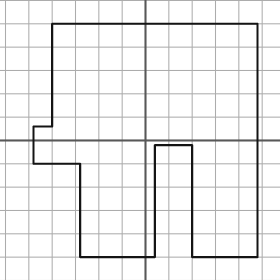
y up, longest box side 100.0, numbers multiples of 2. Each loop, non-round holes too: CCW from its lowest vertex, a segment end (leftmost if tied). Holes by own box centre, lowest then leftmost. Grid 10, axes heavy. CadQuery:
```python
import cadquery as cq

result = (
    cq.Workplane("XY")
    .moveTo(-28.0, -50.0)
    .lineTo(4.0, -50.0)
    .lineTo(4.0, -2.0)
    .lineTo(20.0, -2.0)
    .lineTo(20.0, -50.0)
    .lineTo(48.0, -50.0)
    .lineTo(48.0, 50.0)
    .lineTo(-40.0, 50.0)
    .lineTo(-40.0, 6.0)
    .lineTo(-48.0, 6.0)
    .lineTo(-48.0, -10.0)
    .lineTo(-28.0, -10.0)
    .close()
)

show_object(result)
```